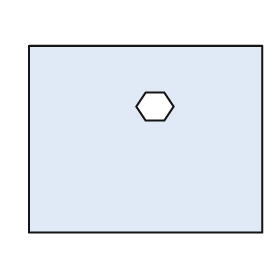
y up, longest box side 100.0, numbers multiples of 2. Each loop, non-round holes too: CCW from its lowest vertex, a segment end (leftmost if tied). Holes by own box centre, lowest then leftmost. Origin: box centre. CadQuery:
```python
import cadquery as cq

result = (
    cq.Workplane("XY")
    .moveTo(-50.0, -40.0)
    .lineTo(50.0, -40.0)
    .lineTo(50.0, 40.0)
    .lineTo(-50.0, 40.0)
    .close()
    .moveTo(0.0, 8.0)
    .lineTo(8.0, 8.0)
    .lineTo(12.0, 14.0)
    .lineTo(8.0, 20.0)
    .lineTo(0.0, 20.0)
    .lineTo(-4.0, 14.0)
    .close()
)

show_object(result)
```